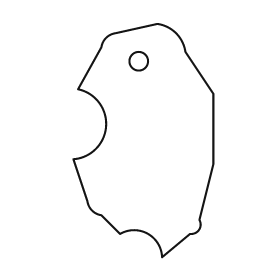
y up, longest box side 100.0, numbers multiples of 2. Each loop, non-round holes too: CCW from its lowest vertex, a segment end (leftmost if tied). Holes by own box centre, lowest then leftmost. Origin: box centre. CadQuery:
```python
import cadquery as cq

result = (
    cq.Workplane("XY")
    .moveTo(8.0, -50.0)
    .lineTo(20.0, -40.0)
    .threePointArc((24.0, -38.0), (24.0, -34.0))
    .lineTo(30.0, -10.0)
    .lineTo(30.0, 20.0)
    .lineTo(18.0, 38.0)
    .threePointArc((14.0, 46.0), (6.0, 50.0))
    .lineTo(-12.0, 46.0)
    .threePointArc((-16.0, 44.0), (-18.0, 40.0))
    .lineTo(-28.0, 22.0)
    .threePointArc((-16.0, 6.0), (-30.0, -8.0))
    .lineTo(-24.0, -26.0)
    .threePointArc((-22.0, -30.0), (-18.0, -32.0))
    .lineTo(-10.0, -40.0)
    .threePointArc((2.0, -40.0), (8.0, -50.0))
    .close()
    .moveTo(-2.0, 34.0)
    .circle(4.0)
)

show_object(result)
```